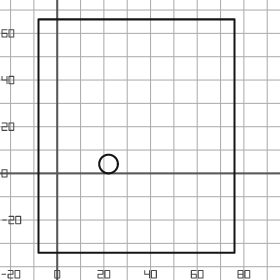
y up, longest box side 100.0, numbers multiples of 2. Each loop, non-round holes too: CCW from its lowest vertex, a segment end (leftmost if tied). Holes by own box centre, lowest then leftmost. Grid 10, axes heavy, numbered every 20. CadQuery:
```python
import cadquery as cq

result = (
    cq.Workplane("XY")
    .moveTo(-8.0, -34.0)
    .lineTo(76.0, -34.0)
    .lineTo(76.0, 66.0)
    .lineTo(-8.0, 66.0)
    .close()
    .moveTo(22.0, 4.0)
    .circle(4.0)
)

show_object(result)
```